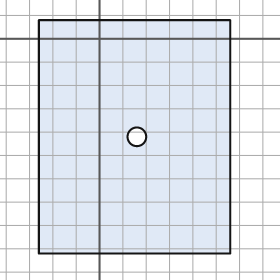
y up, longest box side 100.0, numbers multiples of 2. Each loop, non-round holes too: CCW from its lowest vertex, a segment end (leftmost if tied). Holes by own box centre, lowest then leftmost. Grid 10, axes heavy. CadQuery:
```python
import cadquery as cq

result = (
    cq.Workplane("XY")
    .moveTo(-26.0, -92.0)
    .lineTo(56.0, -92.0)
    .lineTo(56.0, 8.0)
    .lineTo(-26.0, 8.0)
    .close()
    .moveTo(16.0, -42.0)
    .circle(4.0)
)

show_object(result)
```